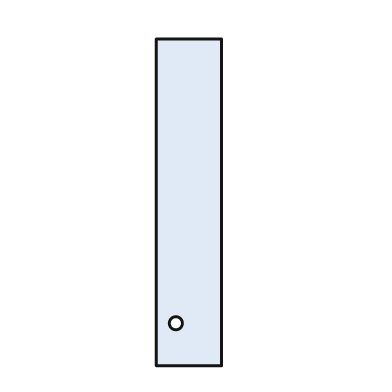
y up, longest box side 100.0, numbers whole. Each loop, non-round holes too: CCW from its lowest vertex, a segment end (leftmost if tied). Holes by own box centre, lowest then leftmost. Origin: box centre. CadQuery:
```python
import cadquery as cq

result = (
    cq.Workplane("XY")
    .moveTo(-10.0, -50.0)
    .lineTo(10.0, -50.0)
    .lineTo(10.0, 50.0)
    .lineTo(-10.0, 50.0)
    .close()
    .moveTo(-4.0, -37.0)
    .circle(2.0)
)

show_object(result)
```